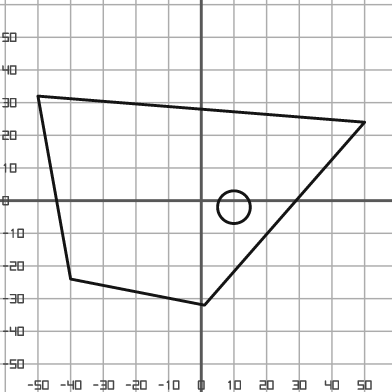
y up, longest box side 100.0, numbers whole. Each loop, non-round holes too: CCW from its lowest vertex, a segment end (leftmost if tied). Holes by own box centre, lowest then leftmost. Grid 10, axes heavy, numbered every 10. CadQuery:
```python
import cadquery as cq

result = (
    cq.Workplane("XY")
    .moveTo(1.0, -32.0)
    .lineTo(50.0, 24.0)
    .lineTo(-50.0, 32.0)
    .lineTo(-40.0, -24.0)
    .close()
    .moveTo(10.0, -2.0)
    .circle(5.0)
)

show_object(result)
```